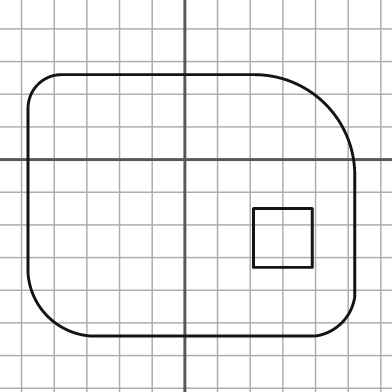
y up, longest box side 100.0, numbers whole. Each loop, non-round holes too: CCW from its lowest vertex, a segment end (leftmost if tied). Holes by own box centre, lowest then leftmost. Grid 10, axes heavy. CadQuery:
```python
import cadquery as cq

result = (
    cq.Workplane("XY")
    .moveTo(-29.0, -54.0)
    .lineTo(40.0, -54.0)
    .threePointArc((48.0, -50.0), (52.0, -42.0))
    .lineTo(52.0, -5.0)
    .threePointArc((43.0, 17.0), (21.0, 26.0))
    .lineTo(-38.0, 26.0)
    .threePointArc((-45.0, 23.0), (-48.0, 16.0))
    .lineTo(-48.0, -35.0)
    .threePointArc((-42.0, -48.0), (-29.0, -54.0))
    .close()
    .moveTo(21.0, -33.0)
    .lineTo(39.0, -33.0)
    .lineTo(39.0, -15.0)
    .lineTo(21.0, -15.0)
    .close()
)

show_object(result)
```